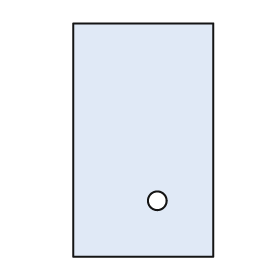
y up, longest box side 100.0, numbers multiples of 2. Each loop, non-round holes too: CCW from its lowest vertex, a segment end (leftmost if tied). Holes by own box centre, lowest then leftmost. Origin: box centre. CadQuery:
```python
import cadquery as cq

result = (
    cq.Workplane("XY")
    .moveTo(-30.0, -50.0)
    .lineTo(30.0, -50.0)
    .lineTo(30.0, 50.0)
    .lineTo(-30.0, 50.0)
    .close()
    .moveTo(6.0, -26.0)
    .circle(4.0)
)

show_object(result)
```